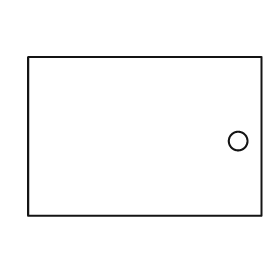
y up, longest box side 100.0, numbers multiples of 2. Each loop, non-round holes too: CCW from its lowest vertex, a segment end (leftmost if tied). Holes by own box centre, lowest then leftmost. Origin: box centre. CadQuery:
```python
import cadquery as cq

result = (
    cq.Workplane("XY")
    .moveTo(-50.0, -34.0)
    .lineTo(50.0, -34.0)
    .lineTo(50.0, 34.0)
    .lineTo(-50.0, 34.0)
    .close()
    .moveTo(40.0, -2.0)
    .circle(4.0)
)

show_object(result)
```